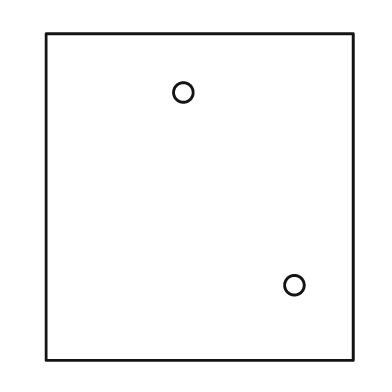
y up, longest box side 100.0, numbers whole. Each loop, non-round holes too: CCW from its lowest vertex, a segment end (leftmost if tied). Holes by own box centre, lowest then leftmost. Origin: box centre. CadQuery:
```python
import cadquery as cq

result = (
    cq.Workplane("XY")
    .moveTo(-47.0, -50.0)
    .lineTo(47.0, -50.0)
    .lineTo(47.0, 50.0)
    .lineTo(-47.0, 50.0)
    .close()
    .moveTo(29.0, -27.0)
    .circle(3.0)
    .moveTo(-5.0, 32.0)
    .circle(3.0)
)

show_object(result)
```